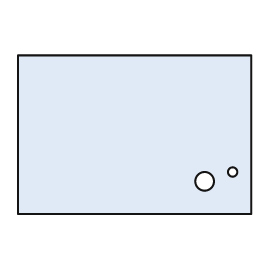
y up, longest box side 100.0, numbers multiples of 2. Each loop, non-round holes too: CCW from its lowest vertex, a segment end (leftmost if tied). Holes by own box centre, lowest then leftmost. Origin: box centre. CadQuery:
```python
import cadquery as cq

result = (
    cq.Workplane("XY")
    .moveTo(-50.0, -34.0)
    .lineTo(50.0, -34.0)
    .lineTo(50.0, 34.0)
    .lineTo(-50.0, 34.0)
    .close()
    .moveTo(30.0, -20.0)
    .circle(4.0)
    .moveTo(42.0, -16.0)
    .circle(2.0)
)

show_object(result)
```